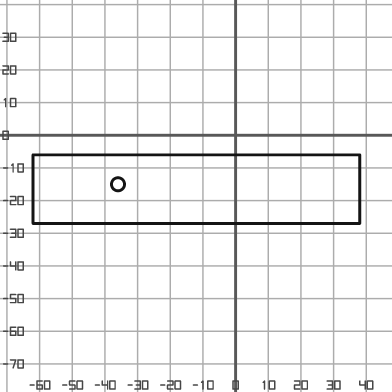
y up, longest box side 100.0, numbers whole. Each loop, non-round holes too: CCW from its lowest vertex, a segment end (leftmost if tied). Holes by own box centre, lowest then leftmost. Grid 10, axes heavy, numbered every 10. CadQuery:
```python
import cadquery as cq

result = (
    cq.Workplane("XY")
    .moveTo(-62.0, -27.0)
    .lineTo(38.0, -27.0)
    .lineTo(38.0, -6.0)
    .lineTo(-62.0, -6.0)
    .close()
    .moveTo(-36.0, -15.0)
    .circle(2.0)
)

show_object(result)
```